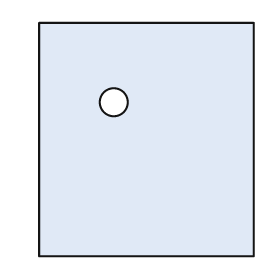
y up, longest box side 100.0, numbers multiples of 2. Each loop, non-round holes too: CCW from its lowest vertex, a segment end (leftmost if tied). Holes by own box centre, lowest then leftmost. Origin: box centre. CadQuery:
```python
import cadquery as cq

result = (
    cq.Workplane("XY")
    .moveTo(-46.0, -50.0)
    .lineTo(46.0, -50.0)
    .lineTo(46.0, 50.0)
    .lineTo(-46.0, 50.0)
    .close()
    .moveTo(-14.0, 16.0)
    .circle(6.0)
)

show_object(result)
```